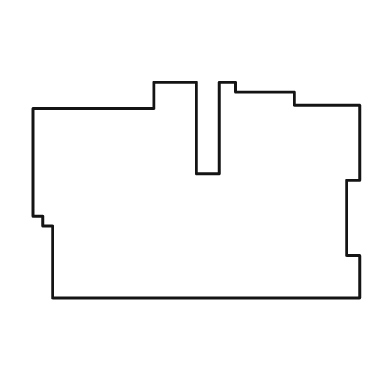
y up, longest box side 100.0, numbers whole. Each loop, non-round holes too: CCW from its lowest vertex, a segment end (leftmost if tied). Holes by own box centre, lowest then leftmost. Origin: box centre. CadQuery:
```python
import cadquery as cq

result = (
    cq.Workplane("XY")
    .moveTo(-44.0, -33.0)
    .lineTo(50.0, -33.0)
    .lineTo(50.0, -20.0)
    .lineTo(46.0, -20.0)
    .lineTo(46.0, 3.0)
    .lineTo(50.0, 3.0)
    .lineTo(50.0, 26.0)
    .lineTo(30.0, 26.0)
    .lineTo(30.0, 30.0)
    .lineTo(12.0, 30.0)
    .lineTo(12.0, 33.0)
    .lineTo(7.0, 33.0)
    .lineTo(7.0, 5.0)
    .lineTo(0.0, 5.0)
    .lineTo(0.0, 33.0)
    .lineTo(-13.0, 33.0)
    .lineTo(-13.0, 25.0)
    .lineTo(-50.0, 25.0)
    .lineTo(-50.0, -8.0)
    .lineTo(-47.0, -8.0)
    .lineTo(-47.0, -11.0)
    .lineTo(-44.0, -11.0)
    .close()
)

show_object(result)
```